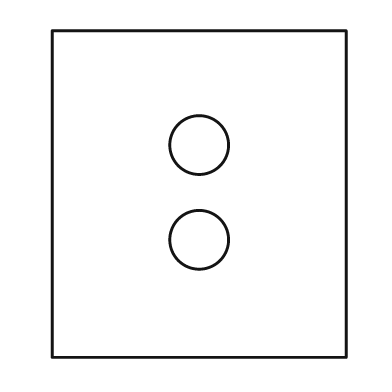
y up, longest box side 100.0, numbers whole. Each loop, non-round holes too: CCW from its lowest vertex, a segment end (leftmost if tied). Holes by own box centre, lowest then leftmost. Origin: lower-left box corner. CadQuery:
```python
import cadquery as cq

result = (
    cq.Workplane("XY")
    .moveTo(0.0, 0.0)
    .lineTo(90.0, 0.0)
    .lineTo(90.0, 100.0)
    .lineTo(0.0, 100.0)
    .close()
    .moveTo(45.0, 36.0)
    .circle(9.0)
    .moveTo(45.0, 65.0)
    .circle(9.0)
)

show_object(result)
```